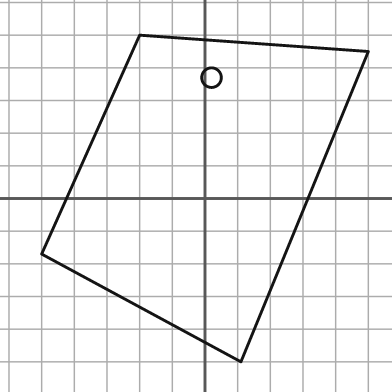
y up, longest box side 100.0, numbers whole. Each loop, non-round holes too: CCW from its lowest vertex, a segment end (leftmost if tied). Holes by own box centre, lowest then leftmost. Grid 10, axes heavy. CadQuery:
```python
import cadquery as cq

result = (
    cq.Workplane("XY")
    .moveTo(11.0, -50.0)
    .lineTo(50.0, 45.0)
    .lineTo(-20.0, 50.0)
    .lineTo(-50.0, -17.0)
    .close()
    .moveTo(2.0, 37.0)
    .circle(3.0)
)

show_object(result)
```